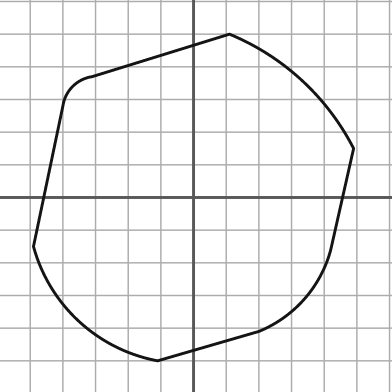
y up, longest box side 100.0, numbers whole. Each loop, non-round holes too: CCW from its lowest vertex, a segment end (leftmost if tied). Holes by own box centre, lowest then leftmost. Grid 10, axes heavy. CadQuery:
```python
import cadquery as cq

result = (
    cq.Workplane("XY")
    .moveTo(-11.0, -50.0)
    .lineTo(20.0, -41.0)
    .threePointArc((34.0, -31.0), (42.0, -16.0))
    .lineTo(49.0, 15.0)
    .threePointArc((33.0, 36.0), (11.0, 50.0))
    .lineTo(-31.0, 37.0)
    .threePointArc((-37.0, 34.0), (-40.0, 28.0))
    .lineTo(-49.0, -15.0)
    .threePointArc((-35.0, -38.0), (-11.0, -50.0))
    .close()
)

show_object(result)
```